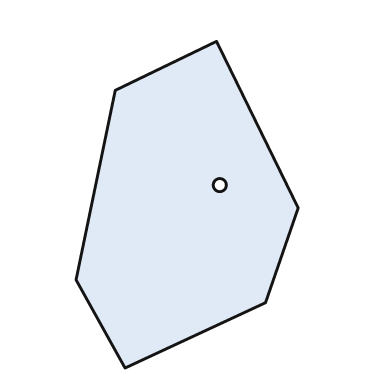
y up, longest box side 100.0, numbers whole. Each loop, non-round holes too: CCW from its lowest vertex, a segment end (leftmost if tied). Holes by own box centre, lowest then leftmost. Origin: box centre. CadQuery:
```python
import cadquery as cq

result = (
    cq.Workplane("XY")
    .moveTo(-19.0, -50.0)
    .lineTo(24.0, -30.0)
    .lineTo(34.0, -1.0)
    .lineTo(9.0, 50.0)
    .lineTo(-22.0, 35.0)
    .lineTo(-34.0, -23.0)
    .close()
    .moveTo(10.0, 6.0)
    .circle(2.0)
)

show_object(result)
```